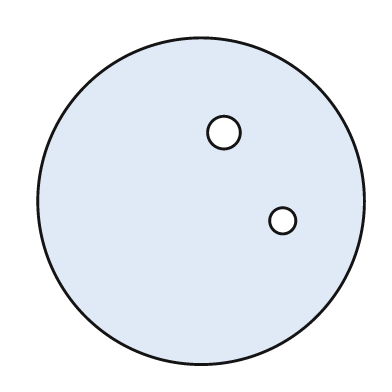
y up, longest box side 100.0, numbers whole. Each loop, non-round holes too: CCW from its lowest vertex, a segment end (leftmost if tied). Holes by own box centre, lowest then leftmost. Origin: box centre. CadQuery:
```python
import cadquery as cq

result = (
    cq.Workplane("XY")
    .moveTo(0.0, 0.0)
    .circle(50.0)
    .moveTo(25.0, -6.0)
    .circle(4.0)
    .moveTo(7.0, 21.0)
    .circle(5.0)
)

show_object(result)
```